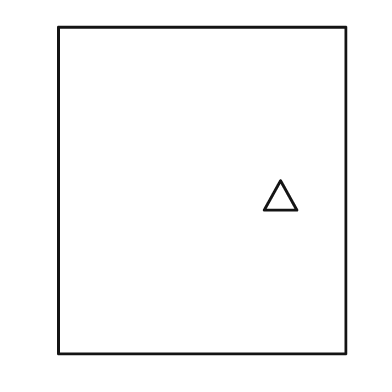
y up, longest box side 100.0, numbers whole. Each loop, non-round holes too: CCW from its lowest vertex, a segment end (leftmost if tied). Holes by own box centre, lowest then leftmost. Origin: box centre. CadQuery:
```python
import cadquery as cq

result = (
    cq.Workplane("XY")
    .moveTo(-44.0, -50.0)
    .lineTo(44.0, -50.0)
    .lineTo(44.0, 50.0)
    .lineTo(-44.0, 50.0)
    .close()
    .moveTo(19.0, -6.0)
    .lineTo(29.0, -6.0)
    .lineTo(24.0, 3.0)
    .close()
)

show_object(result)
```